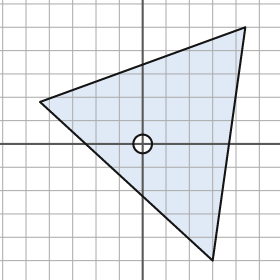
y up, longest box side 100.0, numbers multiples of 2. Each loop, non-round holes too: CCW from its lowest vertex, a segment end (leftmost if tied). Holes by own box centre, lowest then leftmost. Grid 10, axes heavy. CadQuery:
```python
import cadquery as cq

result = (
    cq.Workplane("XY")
    .moveTo(30.0, -50.0)
    .lineTo(44.0, 50.0)
    .lineTo(-44.0, 18.0)
    .close()
    .moveTo(0.0, 0.0)
    .circle(4.0)
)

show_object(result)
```